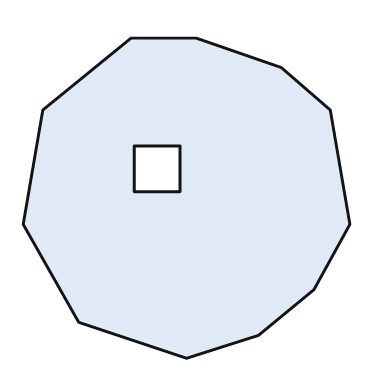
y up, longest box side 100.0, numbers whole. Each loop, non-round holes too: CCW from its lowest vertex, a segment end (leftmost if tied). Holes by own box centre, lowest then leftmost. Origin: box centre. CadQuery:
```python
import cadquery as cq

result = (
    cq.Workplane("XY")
    .moveTo(0.0, -49.0)
    .lineTo(22.0, -42.0)
    .lineTo(39.0, -28.0)
    .lineTo(50.0, -8.0)
    .lineTo(44.0, 27.0)
    .lineTo(29.0, 40.0)
    .lineTo(3.0, 49.0)
    .lineTo(-17.0, 49.0)
    .lineTo(-44.0, 27.0)
    .lineTo(-50.0, -8.0)
    .lineTo(-33.0, -38.0)
    .close()
    .moveTo(-16.0, 2.0)
    .lineTo(-2.0, 2.0)
    .lineTo(-2.0, 16.0)
    .lineTo(-16.0, 16.0)
    .close()
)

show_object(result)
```